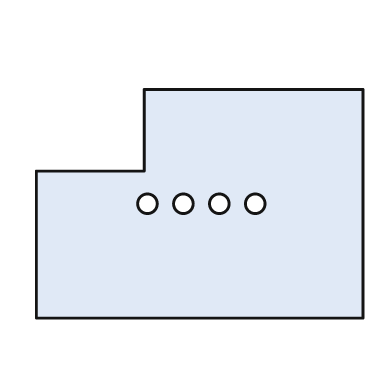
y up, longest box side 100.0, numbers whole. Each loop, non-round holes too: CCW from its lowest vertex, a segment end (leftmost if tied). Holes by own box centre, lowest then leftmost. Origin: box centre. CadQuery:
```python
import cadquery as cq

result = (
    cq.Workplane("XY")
    .moveTo(-50.0, -35.0)
    .lineTo(50.0, -35.0)
    .lineTo(50.0, 35.0)
    .lineTo(-17.0, 35.0)
    .lineTo(-17.0, 10.0)
    .lineTo(-50.0, 10.0)
    .close()
    .moveTo(-16.0, 0.0)
    .circle(3.0)
    .moveTo(-5.0, 0.0)
    .circle(3.0)
    .moveTo(6.0, 0.0)
    .circle(3.0)
    .moveTo(17.0, 0.0)
    .circle(3.0)
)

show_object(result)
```